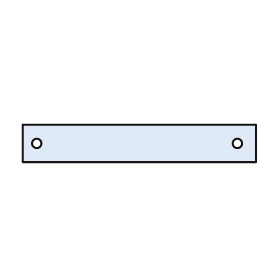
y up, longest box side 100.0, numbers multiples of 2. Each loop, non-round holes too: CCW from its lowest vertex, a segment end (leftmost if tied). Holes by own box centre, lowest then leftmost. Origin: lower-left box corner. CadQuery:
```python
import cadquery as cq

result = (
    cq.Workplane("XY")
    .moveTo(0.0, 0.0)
    .lineTo(100.0, 0.0)
    .lineTo(100.0, 16.0)
    .lineTo(0.0, 16.0)
    .close()
    .moveTo(6.0, 8.0)
    .circle(2.0)
    .moveTo(92.0, 8.0)
    .circle(2.0)
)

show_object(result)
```